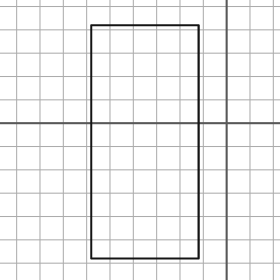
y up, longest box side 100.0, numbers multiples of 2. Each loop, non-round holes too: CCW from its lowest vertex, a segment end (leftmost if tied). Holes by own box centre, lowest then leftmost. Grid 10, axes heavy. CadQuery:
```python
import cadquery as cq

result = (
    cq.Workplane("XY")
    .moveTo(-58.0, -58.0)
    .lineTo(-12.0, -58.0)
    .lineTo(-12.0, 42.0)
    .lineTo(-58.0, 42.0)
    .close()
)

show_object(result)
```